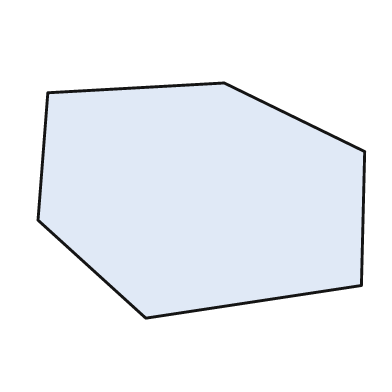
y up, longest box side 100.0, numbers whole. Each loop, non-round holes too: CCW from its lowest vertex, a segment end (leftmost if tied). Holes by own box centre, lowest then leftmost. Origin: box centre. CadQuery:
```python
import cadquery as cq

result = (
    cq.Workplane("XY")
    .moveTo(-17.0, -36.0)
    .lineTo(49.0, -26.0)
    .lineTo(50.0, 15.0)
    .lineTo(7.0, 36.0)
    .lineTo(-47.0, 33.0)
    .lineTo(-50.0, -6.0)
    .close()
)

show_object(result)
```